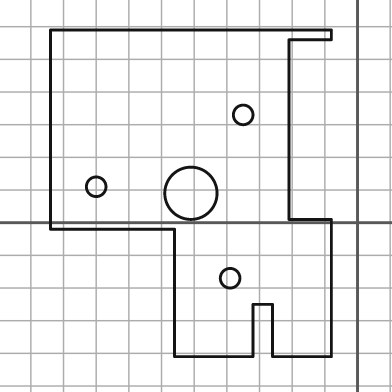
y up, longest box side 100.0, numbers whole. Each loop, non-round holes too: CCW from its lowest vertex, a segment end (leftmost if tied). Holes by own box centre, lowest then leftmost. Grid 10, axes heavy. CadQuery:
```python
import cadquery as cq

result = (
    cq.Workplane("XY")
    .moveTo(-56.0, -41.0)
    .lineTo(-32.0, -41.0)
    .lineTo(-32.0, -25.0)
    .lineTo(-26.0, -25.0)
    .lineTo(-26.0, -41.0)
    .lineTo(-8.0, -41.0)
    .lineTo(-8.0, 1.0)
    .lineTo(-21.0, 1.0)
    .lineTo(-21.0, 56.0)
    .lineTo(-8.0, 56.0)
    .lineTo(-8.0, 59.0)
    .lineTo(-94.0, 59.0)
    .lineTo(-94.0, -2.0)
    .lineTo(-56.0, -2.0)
    .close()
    .moveTo(-39.0, -17.0)
    .circle(3.0)
    .moveTo(-51.0, 9.0)
    .circle(8.0)
    .moveTo(-80.0, 11.0)
    .circle(3.0)
    .moveTo(-35.0, 33.0)
    .circle(3.0)
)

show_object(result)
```